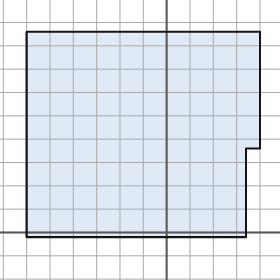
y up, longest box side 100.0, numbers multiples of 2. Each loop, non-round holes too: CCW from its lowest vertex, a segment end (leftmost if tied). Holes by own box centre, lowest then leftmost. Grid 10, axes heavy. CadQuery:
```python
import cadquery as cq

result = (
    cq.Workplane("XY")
    .moveTo(-60.0, -2.0)
    .lineTo(34.0, -2.0)
    .lineTo(34.0, 36.0)
    .lineTo(40.0, 36.0)
    .lineTo(40.0, 86.0)
    .lineTo(-60.0, 86.0)
    .close()
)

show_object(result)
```